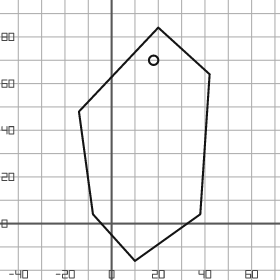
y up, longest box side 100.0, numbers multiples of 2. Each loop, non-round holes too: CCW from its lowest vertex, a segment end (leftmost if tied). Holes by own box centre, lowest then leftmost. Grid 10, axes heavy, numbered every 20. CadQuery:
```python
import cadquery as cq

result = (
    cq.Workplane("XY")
    .moveTo(10.0, -16.0)
    .lineTo(38.0, 4.0)
    .lineTo(42.0, 64.0)
    .lineTo(20.0, 84.0)
    .lineTo(-14.0, 48.0)
    .lineTo(-8.0, 4.0)
    .close()
    .moveTo(18.0, 70.0)
    .circle(2.0)
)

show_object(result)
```